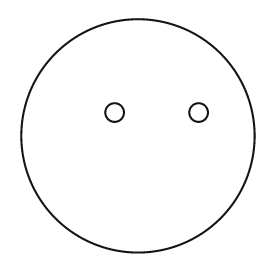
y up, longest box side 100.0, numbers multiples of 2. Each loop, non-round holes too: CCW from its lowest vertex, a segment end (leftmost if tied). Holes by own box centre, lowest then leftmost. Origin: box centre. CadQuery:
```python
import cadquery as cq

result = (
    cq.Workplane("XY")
    .moveTo(0.0, 0.0)
    .circle(50.0)
    .moveTo(-10.0, 10.0)
    .circle(4.0)
    .moveTo(26.0, 10.0)
    .circle(4.0)
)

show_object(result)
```